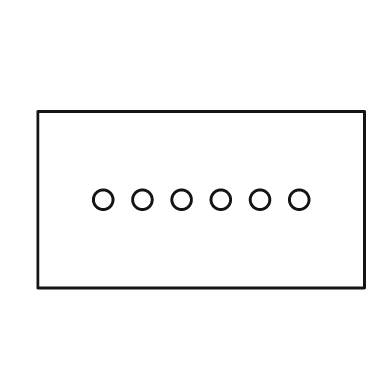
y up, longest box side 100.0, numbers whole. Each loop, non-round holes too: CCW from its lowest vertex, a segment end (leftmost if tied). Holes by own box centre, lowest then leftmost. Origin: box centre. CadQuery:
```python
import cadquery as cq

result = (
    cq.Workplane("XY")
    .moveTo(-50.0, -27.0)
    .lineTo(50.0, -27.0)
    .lineTo(50.0, 27.0)
    .lineTo(-50.0, 27.0)
    .close()
    .moveTo(-30.0, 0.0)
    .circle(3.0)
    .moveTo(-18.0, 0.0)
    .circle(3.0)
    .moveTo(-6.0, 0.0)
    .circle(3.0)
    .moveTo(6.0, 0.0)
    .circle(3.0)
    .moveTo(18.0, 0.0)
    .circle(3.0)
    .moveTo(30.0, 0.0)
    .circle(3.0)
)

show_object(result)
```